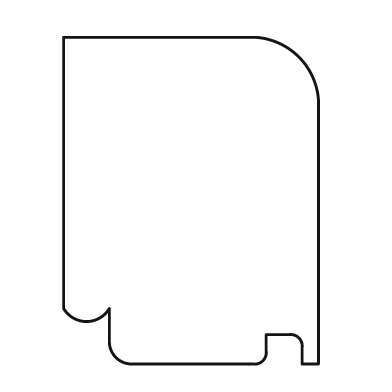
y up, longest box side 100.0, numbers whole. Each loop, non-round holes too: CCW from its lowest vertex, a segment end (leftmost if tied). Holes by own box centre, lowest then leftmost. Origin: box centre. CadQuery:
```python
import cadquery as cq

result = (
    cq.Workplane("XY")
    .moveTo(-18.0, -50.0)
    .lineTo(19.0, -50.0)
    .threePointArc((22.0, -49.0), (23.0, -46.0))
    .lineTo(23.0, -41.0)
    .lineTo(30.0, -41.0)
    .threePointArc((33.0, -42.0), (34.0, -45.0))
    .lineTo(34.0, -50.0)
    .lineTo(39.0, -50.0)
    .lineTo(39.0, 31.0)
    .threePointArc((33.0, 44.0), (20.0, 50.0))
    .lineTo(-39.0, 50.0)
    .lineTo(-39.0, -33.0)
    .threePointArc((-32.0, -37.0), (-25.0, -33.0))
    .lineTo(-25.0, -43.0)
    .threePointArc((-23.0, -48.0), (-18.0, -50.0))
    .close()
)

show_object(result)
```